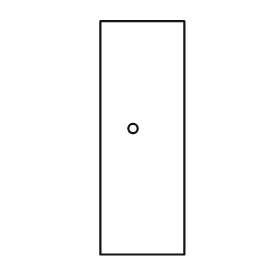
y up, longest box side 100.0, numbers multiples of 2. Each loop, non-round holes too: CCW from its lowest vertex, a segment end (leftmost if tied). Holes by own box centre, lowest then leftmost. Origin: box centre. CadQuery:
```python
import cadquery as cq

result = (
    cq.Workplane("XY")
    .moveTo(-18.0, -50.0)
    .lineTo(18.0, -50.0)
    .lineTo(18.0, 50.0)
    .lineTo(-18.0, 50.0)
    .close()
    .moveTo(-4.0, 4.0)
    .circle(2.0)
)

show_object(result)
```